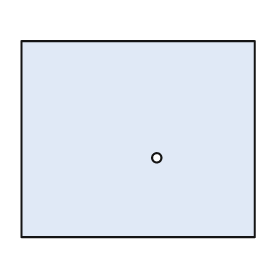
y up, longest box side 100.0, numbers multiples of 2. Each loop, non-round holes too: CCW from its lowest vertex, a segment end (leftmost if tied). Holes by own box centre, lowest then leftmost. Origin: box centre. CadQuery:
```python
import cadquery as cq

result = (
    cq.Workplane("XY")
    .moveTo(-50.0, -42.0)
    .lineTo(50.0, -42.0)
    .lineTo(50.0, 42.0)
    .lineTo(-50.0, 42.0)
    .close()
    .moveTo(8.0, -8.0)
    .circle(2.0)
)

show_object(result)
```